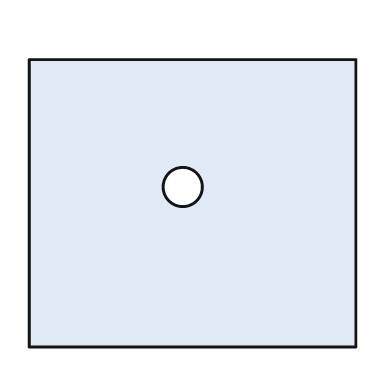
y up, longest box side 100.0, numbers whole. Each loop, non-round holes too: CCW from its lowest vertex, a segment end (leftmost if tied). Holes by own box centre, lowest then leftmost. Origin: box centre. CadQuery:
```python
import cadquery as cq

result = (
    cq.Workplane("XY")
    .moveTo(-50.0, -44.0)
    .lineTo(50.0, -44.0)
    .lineTo(50.0, 44.0)
    .lineTo(-50.0, 44.0)
    .close()
    .moveTo(-3.0, 5.0)
    .circle(6.0)
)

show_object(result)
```